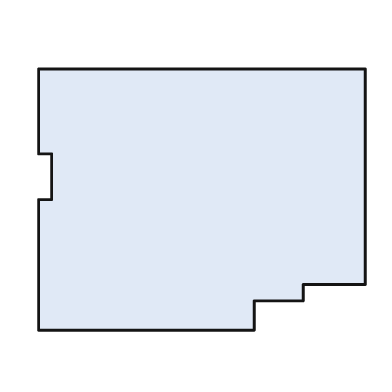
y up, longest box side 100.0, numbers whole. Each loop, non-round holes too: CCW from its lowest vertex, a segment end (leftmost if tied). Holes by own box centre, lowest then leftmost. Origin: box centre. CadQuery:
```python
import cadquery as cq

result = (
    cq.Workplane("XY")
    .moveTo(-50.0, -40.0)
    .lineTo(16.0, -40.0)
    .lineTo(16.0, -31.0)
    .lineTo(31.0, -31.0)
    .lineTo(31.0, -26.0)
    .lineTo(50.0, -26.0)
    .lineTo(50.0, 40.0)
    .lineTo(-50.0, 40.0)
    .lineTo(-50.0, 14.0)
    .lineTo(-46.0, 14.0)
    .lineTo(-46.0, 0.0)
    .lineTo(-50.0, 0.0)
    .close()
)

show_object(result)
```